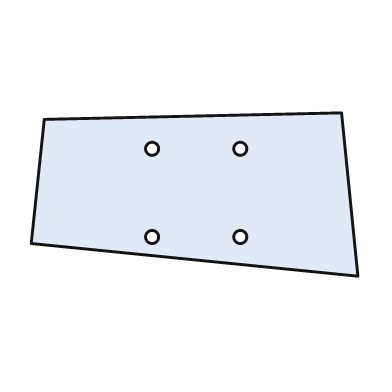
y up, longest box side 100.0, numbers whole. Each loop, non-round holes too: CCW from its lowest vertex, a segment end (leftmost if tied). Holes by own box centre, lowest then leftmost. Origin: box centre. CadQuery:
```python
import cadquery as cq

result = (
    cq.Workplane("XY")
    .moveTo(50.0, -25.0)
    .lineTo(45.0, 25.0)
    .lineTo(-46.0, 23.0)
    .lineTo(-50.0, -15.0)
    .close()
    .moveTo(-13.0, -13.0)
    .circle(2.0)
    .moveTo(14.0, -13.0)
    .circle(2.0)
    .moveTo(-13.0, 14.0)
    .circle(2.0)
    .moveTo(14.0, 14.0)
    .circle(2.0)
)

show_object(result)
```